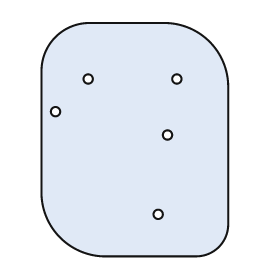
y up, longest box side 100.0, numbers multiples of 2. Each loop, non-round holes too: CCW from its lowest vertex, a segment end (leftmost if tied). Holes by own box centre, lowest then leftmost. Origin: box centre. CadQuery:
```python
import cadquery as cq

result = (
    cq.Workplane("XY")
    .moveTo(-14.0, -50.0)
    .lineTo(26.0, -50.0)
    .threePointArc((36.0, -46.0), (40.0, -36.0))
    .lineTo(40.0, 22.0)
    .threePointArc((32.0, 42.0), (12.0, 50.0))
    .lineTo(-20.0, 50.0)
    .threePointArc((-34.0, 44.0), (-40.0, 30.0))
    .lineTo(-40.0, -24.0)
    .threePointArc((-32.0, -42.0), (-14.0, -50.0))
    .close()
    .moveTo(10.0, -32.0)
    .circle(2.0)
    .moveTo(14.0, 2.0)
    .circle(2.0)
    .moveTo(-34.0, 12.0)
    .circle(2.0)
    .moveTo(-20.0, 26.0)
    .circle(2.0)
    .moveTo(18.0, 26.0)
    .circle(2.0)
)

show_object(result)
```